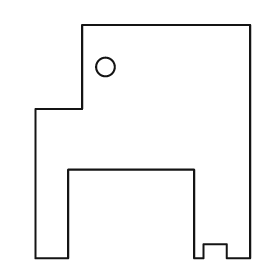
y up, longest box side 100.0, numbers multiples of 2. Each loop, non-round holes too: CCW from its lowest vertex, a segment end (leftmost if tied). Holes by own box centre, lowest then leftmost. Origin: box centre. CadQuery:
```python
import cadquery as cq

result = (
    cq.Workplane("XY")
    .moveTo(-46.0, -50.0)
    .lineTo(-32.0, -50.0)
    .lineTo(-32.0, -12.0)
    .lineTo(22.0, -12.0)
    .lineTo(22.0, -50.0)
    .lineTo(26.0, -50.0)
    .lineTo(26.0, -44.0)
    .lineTo(36.0, -44.0)
    .lineTo(36.0, -50.0)
    .lineTo(46.0, -50.0)
    .lineTo(46.0, 50.0)
    .lineTo(-26.0, 50.0)
    .lineTo(-26.0, 14.0)
    .lineTo(-46.0, 14.0)
    .close()
    .moveTo(-16.0, 32.0)
    .circle(4.0)
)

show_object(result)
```